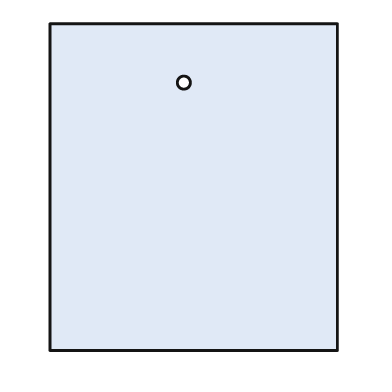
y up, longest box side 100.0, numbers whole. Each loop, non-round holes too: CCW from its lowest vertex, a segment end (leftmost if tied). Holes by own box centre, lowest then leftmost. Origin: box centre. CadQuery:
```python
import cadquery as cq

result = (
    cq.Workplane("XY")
    .moveTo(-44.0, -50.0)
    .lineTo(44.0, -50.0)
    .lineTo(44.0, 50.0)
    .lineTo(-44.0, 50.0)
    .close()
    .moveTo(-3.0, 32.0)
    .circle(2.0)
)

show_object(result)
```